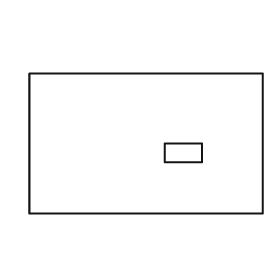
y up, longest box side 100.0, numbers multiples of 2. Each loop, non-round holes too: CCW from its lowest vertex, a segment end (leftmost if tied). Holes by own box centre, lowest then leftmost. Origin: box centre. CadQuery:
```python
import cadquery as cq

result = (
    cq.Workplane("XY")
    .moveTo(-50.0, -30.0)
    .lineTo(50.0, -30.0)
    .lineTo(50.0, 30.0)
    .lineTo(-50.0, 30.0)
    .close()
    .moveTo(8.0, -8.0)
    .lineTo(24.0, -8.0)
    .lineTo(24.0, 0.0)
    .lineTo(8.0, 0.0)
    .close()
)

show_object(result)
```